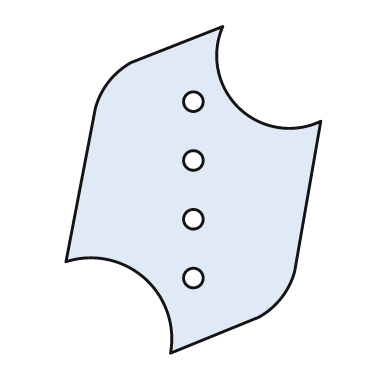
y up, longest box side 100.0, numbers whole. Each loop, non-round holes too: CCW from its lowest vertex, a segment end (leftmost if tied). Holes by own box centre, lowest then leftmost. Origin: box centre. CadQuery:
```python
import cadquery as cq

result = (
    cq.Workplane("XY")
    .moveTo(-7.0, -50.0)
    .lineTo(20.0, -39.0)
    .threePointArc((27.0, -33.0), (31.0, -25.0))
    .lineTo(39.0, 21.0)
    .threePointArc((14.0, 25.0), (9.0, 50.0))
    .lineTo(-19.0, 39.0)
    .threePointArc((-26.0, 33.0), (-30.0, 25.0))
    .lineTo(-39.0, -22.0)
    .threePointArc((-15.0, -27.0), (-7.0, -50.0))
    .close()
    .moveTo(0.0, -27.0)
    .circle(3.0)
    .moveTo(0.0, -9.0)
    .circle(3.0)
    .moveTo(0.0, 9.0)
    .circle(3.0)
    .moveTo(0.0, 27.0)
    .circle(3.0)
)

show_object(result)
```